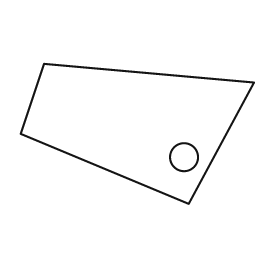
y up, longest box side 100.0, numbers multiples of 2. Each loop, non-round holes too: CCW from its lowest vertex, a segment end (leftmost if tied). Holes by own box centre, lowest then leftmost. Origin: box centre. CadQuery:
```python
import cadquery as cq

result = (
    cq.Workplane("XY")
    .moveTo(22.0, -30.0)
    .lineTo(50.0, 22.0)
    .lineTo(-40.0, 30.0)
    .lineTo(-50.0, 0.0)
    .close()
    .moveTo(20.0, -10.0)
    .circle(6.0)
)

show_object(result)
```